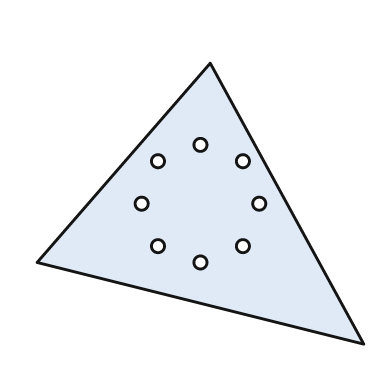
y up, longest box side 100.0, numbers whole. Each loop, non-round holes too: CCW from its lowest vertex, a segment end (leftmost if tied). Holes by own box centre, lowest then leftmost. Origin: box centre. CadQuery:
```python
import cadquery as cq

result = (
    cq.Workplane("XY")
    .moveTo(50.0, -43.0)
    .lineTo(3.0, 43.0)
    .lineTo(-50.0, -18.0)
    .close()
    .moveTo(0.0, -18.0)
    .circle(2.0)
    .moveTo(-13.0, -13.0)
    .circle(2.0)
    .moveTo(13.0, -13.0)
    .circle(2.0)
    .moveTo(-18.0, 0.0)
    .circle(2.0)
    .moveTo(18.0, 0.0)
    .circle(2.0)
    .moveTo(-13.0, 13.0)
    .circle(2.0)
    .moveTo(13.0, 13.0)
    .circle(2.0)
    .moveTo(0.0, 18.0)
    .circle(2.0)
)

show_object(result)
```